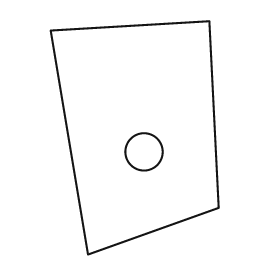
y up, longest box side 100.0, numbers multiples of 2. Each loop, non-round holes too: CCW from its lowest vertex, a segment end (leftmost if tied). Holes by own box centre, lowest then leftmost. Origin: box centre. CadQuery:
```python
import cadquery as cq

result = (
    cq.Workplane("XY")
    .moveTo(-20.0, -50.0)
    .lineTo(36.0, -30.0)
    .lineTo(32.0, 50.0)
    .lineTo(-36.0, 46.0)
    .close()
    .moveTo(4.0, -6.0)
    .circle(8.0)
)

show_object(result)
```